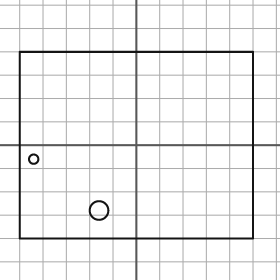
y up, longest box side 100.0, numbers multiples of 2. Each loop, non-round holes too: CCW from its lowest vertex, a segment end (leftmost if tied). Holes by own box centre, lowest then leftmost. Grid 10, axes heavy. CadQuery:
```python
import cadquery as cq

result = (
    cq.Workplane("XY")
    .moveTo(-50.0, -40.0)
    .lineTo(50.0, -40.0)
    .lineTo(50.0, 40.0)
    .lineTo(-50.0, 40.0)
    .close()
    .moveTo(-16.0, -28.0)
    .circle(4.0)
    .moveTo(-44.0, -6.0)
    .circle(2.0)
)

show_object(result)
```